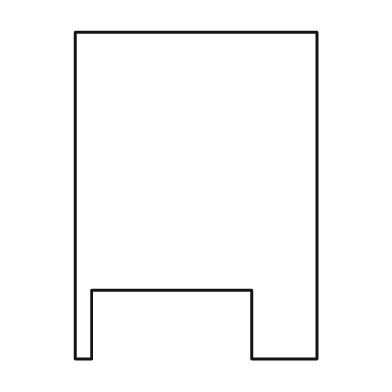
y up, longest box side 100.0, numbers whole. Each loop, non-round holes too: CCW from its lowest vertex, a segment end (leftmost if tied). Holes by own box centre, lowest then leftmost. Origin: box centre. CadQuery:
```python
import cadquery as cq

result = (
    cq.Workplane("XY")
    .moveTo(-37.0, -50.0)
    .lineTo(-32.0, -50.0)
    .lineTo(-32.0, -29.0)
    .lineTo(17.0, -29.0)
    .lineTo(17.0, -50.0)
    .lineTo(37.0, -50.0)
    .lineTo(37.0, 50.0)
    .lineTo(-37.0, 50.0)
    .close()
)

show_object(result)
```